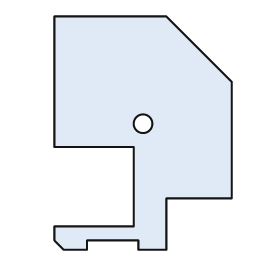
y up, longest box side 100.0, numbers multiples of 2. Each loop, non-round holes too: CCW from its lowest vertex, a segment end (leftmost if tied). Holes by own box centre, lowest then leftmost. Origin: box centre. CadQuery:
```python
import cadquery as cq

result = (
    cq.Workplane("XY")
    .moveTo(-34.0, -50.0)
    .lineTo(-24.0, -50.0)
    .lineTo(-24.0, -46.0)
    .lineTo(-2.0, -46.0)
    .lineTo(-2.0, -50.0)
    .lineTo(10.0, -50.0)
    .lineTo(10.0, -28.0)
    .lineTo(38.0, -28.0)
    .lineTo(38.0, 22.0)
    .lineTo(10.0, 50.0)
    .lineTo(-38.0, 50.0)
    .lineTo(-38.0, -6.0)
    .lineTo(-4.0, -6.0)
    .lineTo(-4.0, -40.0)
    .lineTo(-38.0, -40.0)
    .lineTo(-38.0, -46.0)
    .close()
    .moveTo(0.0, 4.0)
    .circle(4.0)
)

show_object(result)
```